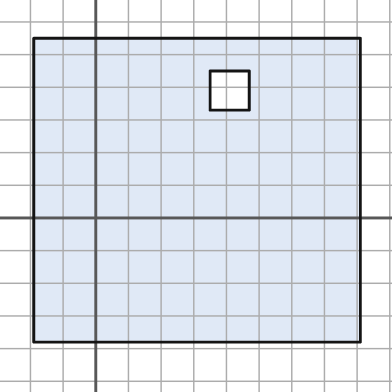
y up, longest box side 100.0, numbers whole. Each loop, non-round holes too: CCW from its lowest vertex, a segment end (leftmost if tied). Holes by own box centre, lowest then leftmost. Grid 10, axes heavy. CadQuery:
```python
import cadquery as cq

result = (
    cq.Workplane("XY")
    .moveTo(-19.0, -38.0)
    .lineTo(81.0, -38.0)
    .lineTo(81.0, 55.0)
    .lineTo(-19.0, 55.0)
    .close()
    .moveTo(35.0, 33.0)
    .lineTo(47.0, 33.0)
    .lineTo(47.0, 45.0)
    .lineTo(35.0, 45.0)
    .close()
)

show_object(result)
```